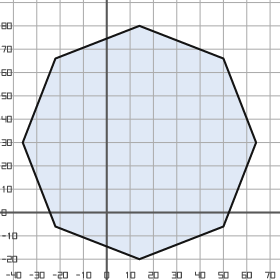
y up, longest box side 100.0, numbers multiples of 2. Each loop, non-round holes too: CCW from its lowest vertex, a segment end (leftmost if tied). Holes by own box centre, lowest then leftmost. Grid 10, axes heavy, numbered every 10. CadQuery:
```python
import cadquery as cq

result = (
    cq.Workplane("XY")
    .moveTo(14.0, -20.0)
    .lineTo(50.0, -6.0)
    .lineTo(64.0, 30.0)
    .lineTo(50.0, 66.0)
    .lineTo(14.0, 80.0)
    .lineTo(-22.0, 66.0)
    .lineTo(-36.0, 30.0)
    .lineTo(-22.0, -6.0)
    .close()
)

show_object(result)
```